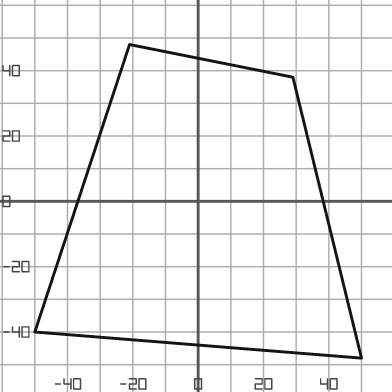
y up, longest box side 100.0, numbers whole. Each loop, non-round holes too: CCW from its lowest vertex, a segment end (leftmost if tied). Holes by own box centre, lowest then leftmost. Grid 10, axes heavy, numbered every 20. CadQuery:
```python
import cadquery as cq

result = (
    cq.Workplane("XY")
    .moveTo(50.0, -48.0)
    .lineTo(29.0, 38.0)
    .lineTo(-21.0, 48.0)
    .lineTo(-50.0, -40.0)
    .close()
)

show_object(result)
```